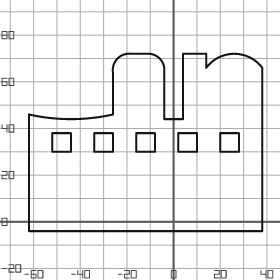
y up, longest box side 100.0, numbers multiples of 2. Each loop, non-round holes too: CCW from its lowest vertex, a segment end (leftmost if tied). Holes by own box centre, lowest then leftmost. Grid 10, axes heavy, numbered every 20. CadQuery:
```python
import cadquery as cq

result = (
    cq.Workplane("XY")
    .moveTo(-62.0, -4.0)
    .lineTo(38.0, -4.0)
    .lineTo(38.0, 66.0)
    .threePointArc((26.0, 72.0), (14.0, 66.0))
    .lineTo(14.0, 72.0)
    .lineTo(4.0, 72.0)
    .lineTo(4.0, 44.0)
    .lineTo(-4.0, 44.0)
    .lineTo(-4.0, 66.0)
    .threePointArc((-6.0, 70.0), (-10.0, 72.0))
    .lineTo(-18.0, 72.0)
    .threePointArc((-24.0, 70.0), (-26.0, 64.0))
    .lineTo(-26.0, 46.0)
    .threePointArc((-44.0, 44.0), (-62.0, 46.0))
    .close()
    .moveTo(-52.0, 30.0)
    .lineTo(-44.0, 30.0)
    .lineTo(-44.0, 38.0)
    .lineTo(-52.0, 38.0)
    .close()
    .moveTo(-34.0, 30.0)
    .lineTo(-26.0, 30.0)
    .lineTo(-26.0, 38.0)
    .lineTo(-34.0, 38.0)
    .close()
    .moveTo(-16.0, 30.0)
    .lineTo(-8.0, 30.0)
    .lineTo(-8.0, 38.0)
    .lineTo(-16.0, 38.0)
    .close()
    .moveTo(2.0, 30.0)
    .lineTo(10.0, 30.0)
    .lineTo(10.0, 38.0)
    .lineTo(2.0, 38.0)
    .close()
    .moveTo(20.0, 30.0)
    .lineTo(28.0, 30.0)
    .lineTo(28.0, 38.0)
    .lineTo(20.0, 38.0)
    .close()
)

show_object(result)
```